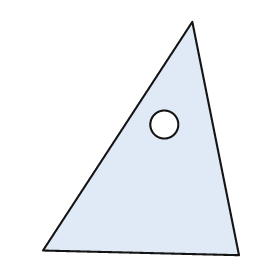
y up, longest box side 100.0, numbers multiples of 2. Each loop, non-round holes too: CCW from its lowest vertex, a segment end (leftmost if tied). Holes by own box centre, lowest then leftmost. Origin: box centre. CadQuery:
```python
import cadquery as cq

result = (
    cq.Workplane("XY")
    .moveTo(42.0, -50.0)
    .lineTo(22.0, 50.0)
    .lineTo(-42.0, -48.0)
    .close()
    .moveTo(10.0, 6.0)
    .circle(6.0)
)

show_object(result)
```